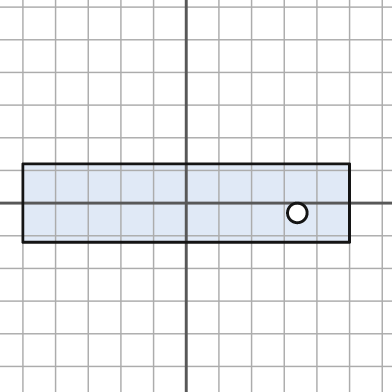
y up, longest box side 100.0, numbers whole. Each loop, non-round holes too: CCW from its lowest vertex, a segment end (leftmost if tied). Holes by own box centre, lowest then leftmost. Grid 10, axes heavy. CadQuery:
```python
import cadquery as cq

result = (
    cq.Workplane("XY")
    .moveTo(-50.0, -12.0)
    .lineTo(50.0, -12.0)
    .lineTo(50.0, 12.0)
    .lineTo(-50.0, 12.0)
    .close()
    .moveTo(34.0, -3.0)
    .circle(3.0)
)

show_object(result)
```